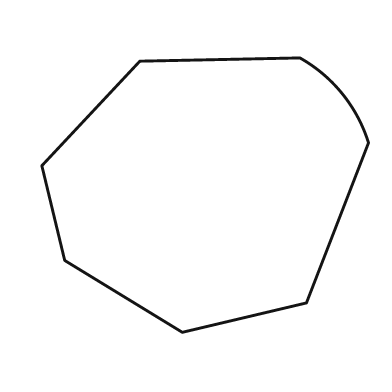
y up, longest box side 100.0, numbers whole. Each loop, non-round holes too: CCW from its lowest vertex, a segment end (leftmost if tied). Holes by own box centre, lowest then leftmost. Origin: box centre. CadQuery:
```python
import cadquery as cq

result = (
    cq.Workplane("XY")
    .moveTo(-7.0, -42.0)
    .lineTo(31.0, -33.0)
    .lineTo(50.0, 16.0)
    .threePointArc((42.0, 31.0), (29.0, 42.0))
    .lineTo(-20.0, 41.0)
    .lineTo(-50.0, 9.0)
    .lineTo(-43.0, -20.0)
    .close()
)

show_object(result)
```